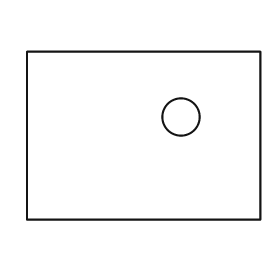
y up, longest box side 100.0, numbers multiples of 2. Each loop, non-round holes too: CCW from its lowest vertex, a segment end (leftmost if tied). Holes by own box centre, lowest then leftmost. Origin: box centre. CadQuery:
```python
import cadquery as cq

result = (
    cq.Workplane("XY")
    .moveTo(-50.0, -36.0)
    .lineTo(50.0, -36.0)
    .lineTo(50.0, 36.0)
    .lineTo(-50.0, 36.0)
    .close()
    .moveTo(16.0, 8.0)
    .circle(8.0)
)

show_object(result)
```